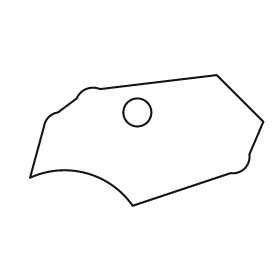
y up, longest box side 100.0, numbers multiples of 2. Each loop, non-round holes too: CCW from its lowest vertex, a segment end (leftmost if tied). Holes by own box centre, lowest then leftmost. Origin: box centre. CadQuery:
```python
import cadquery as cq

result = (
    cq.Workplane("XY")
    .moveTo(-6.0, -28.0)
    .lineTo(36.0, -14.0)
    .threePointArc((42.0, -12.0), (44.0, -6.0))
    .lineTo(50.0, 8.0)
    .lineTo(30.0, 28.0)
    .lineTo(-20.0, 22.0)
    .threePointArc((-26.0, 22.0), (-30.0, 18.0))
    .lineTo(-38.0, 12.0)
    .threePointArc((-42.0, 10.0), (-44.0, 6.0))
    .lineTo(-50.0, -16.0)
    .threePointArc((-26.0, -14.0), (-6.0, -28.0))
    .close()
    .moveTo(-4.0, 12.0)
    .circle(6.0)
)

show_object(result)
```